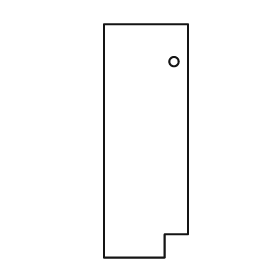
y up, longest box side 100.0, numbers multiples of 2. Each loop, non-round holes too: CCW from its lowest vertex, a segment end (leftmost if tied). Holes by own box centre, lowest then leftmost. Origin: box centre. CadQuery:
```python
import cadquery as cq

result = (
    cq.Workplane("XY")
    .moveTo(-18.0, -50.0)
    .lineTo(8.0, -50.0)
    .lineTo(8.0, -40.0)
    .lineTo(18.0, -40.0)
    .lineTo(18.0, 50.0)
    .lineTo(-18.0, 50.0)
    .close()
    .moveTo(12.0, 34.0)
    .circle(2.0)
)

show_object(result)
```